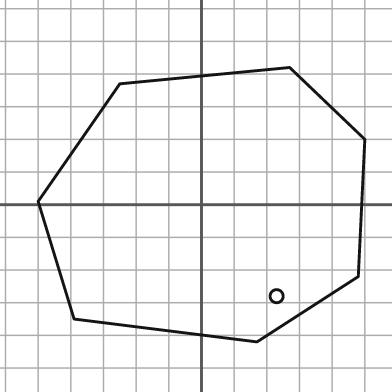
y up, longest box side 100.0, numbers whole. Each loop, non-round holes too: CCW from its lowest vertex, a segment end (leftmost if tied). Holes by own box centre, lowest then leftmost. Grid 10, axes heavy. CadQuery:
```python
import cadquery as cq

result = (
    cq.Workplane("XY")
    .moveTo(17.0, -42.0)
    .lineTo(48.0, -22.0)
    .lineTo(50.0, 20.0)
    .lineTo(27.0, 42.0)
    .lineTo(-25.0, 37.0)
    .lineTo(-50.0, 1.0)
    .lineTo(-39.0, -35.0)
    .close()
    .moveTo(23.0, -28.0)
    .circle(2.0)
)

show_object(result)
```